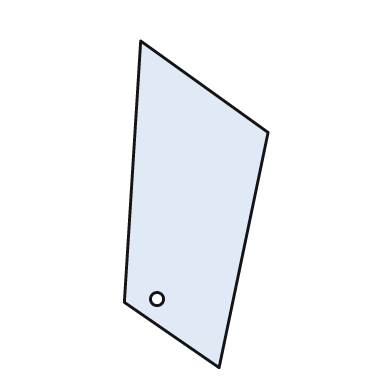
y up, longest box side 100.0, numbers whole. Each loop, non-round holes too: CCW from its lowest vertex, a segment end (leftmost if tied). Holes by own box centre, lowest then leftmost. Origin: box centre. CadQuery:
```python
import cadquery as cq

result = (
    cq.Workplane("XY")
    .moveTo(7.0, -50.0)
    .lineTo(22.0, 22.0)
    .lineTo(-17.0, 50.0)
    .lineTo(-22.0, -30.0)
    .close()
    .moveTo(-12.0, -29.0)
    .circle(2.0)
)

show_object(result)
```